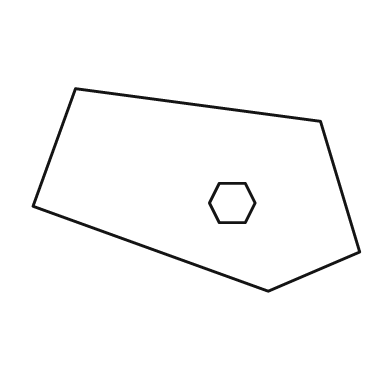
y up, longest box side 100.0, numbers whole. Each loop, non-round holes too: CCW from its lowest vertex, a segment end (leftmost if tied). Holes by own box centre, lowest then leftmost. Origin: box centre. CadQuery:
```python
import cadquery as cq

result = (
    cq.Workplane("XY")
    .moveTo(22.0, -31.0)
    .lineTo(50.0, -19.0)
    .lineTo(38.0, 21.0)
    .lineTo(-37.0, 31.0)
    .lineTo(-50.0, -5.0)
    .close()
    .moveTo(7.0, -10.0)
    .lineTo(15.0, -10.0)
    .lineTo(18.0, -4.0)
    .lineTo(15.0, 2.0)
    .lineTo(7.0, 2.0)
    .lineTo(4.0, -4.0)
    .close()
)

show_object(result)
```